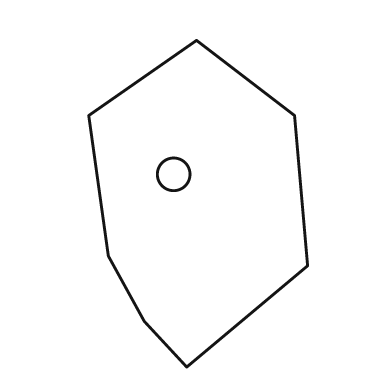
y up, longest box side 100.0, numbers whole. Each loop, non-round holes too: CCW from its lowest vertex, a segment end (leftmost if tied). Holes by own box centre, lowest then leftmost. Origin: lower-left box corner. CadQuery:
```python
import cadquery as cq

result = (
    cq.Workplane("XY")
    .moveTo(30.0, 0.0)
    .lineTo(67.0, 31.0)
    .lineTo(63.0, 77.0)
    .lineTo(33.0, 100.0)
    .lineTo(0.0, 77.0)
    .lineTo(6.0, 34.0)
    .lineTo(17.0, 14.0)
    .close()
    .moveTo(26.0, 59.0)
    .circle(5.0)
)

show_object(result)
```